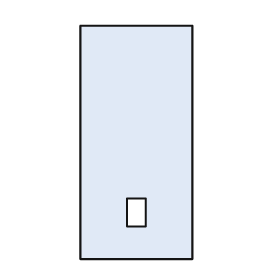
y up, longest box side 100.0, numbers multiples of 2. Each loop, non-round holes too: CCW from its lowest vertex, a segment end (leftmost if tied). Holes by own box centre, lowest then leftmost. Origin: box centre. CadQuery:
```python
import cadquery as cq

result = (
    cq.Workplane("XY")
    .moveTo(-24.0, -50.0)
    .lineTo(24.0, -50.0)
    .lineTo(24.0, 50.0)
    .lineTo(-24.0, 50.0)
    .close()
    .moveTo(-4.0, -36.0)
    .lineTo(4.0, -36.0)
    .lineTo(4.0, -24.0)
    .lineTo(-4.0, -24.0)
    .close()
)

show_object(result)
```